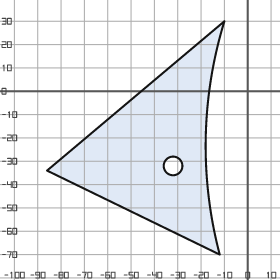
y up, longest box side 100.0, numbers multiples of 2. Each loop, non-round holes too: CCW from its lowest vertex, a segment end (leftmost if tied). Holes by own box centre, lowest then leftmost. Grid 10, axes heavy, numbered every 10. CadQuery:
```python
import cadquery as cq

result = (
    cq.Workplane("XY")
    .moveTo(-12.0, -70.0)
    .threePointArc((-18.0, -20.0), (-10.0, 30.0))
    .lineTo(-86.0, -34.0)
    .close()
    .moveTo(-32.0, -32.0)
    .circle(4.0)
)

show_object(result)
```